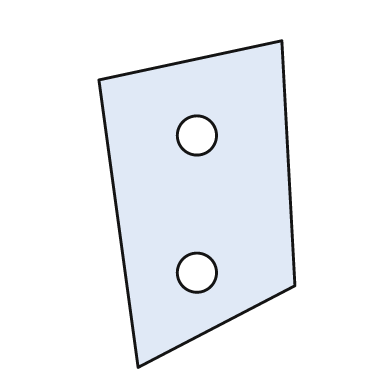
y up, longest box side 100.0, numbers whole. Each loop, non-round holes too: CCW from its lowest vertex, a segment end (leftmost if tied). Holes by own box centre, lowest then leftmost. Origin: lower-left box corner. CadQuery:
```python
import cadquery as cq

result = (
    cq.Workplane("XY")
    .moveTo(12.0, 0.0)
    .lineTo(60.0, 25.0)
    .lineTo(56.0, 100.0)
    .lineTo(0.0, 88.0)
    .close()
    .moveTo(30.0, 29.0)
    .circle(6.0)
    .moveTo(30.0, 71.0)
    .circle(6.0)
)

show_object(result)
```